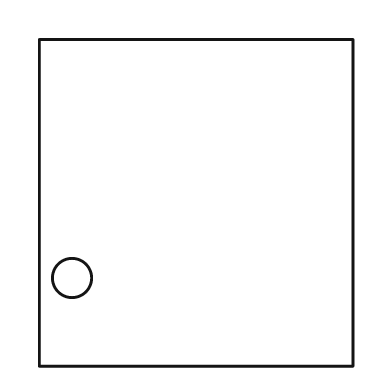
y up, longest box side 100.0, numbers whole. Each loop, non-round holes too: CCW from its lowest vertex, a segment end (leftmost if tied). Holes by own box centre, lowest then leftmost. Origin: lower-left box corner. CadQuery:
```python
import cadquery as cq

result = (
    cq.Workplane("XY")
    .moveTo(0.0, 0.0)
    .lineTo(96.0, 0.0)
    .lineTo(96.0, 100.0)
    .lineTo(0.0, 100.0)
    .close()
    .moveTo(10.0, 27.0)
    .circle(6.0)
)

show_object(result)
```